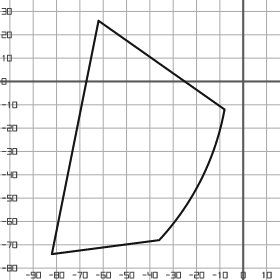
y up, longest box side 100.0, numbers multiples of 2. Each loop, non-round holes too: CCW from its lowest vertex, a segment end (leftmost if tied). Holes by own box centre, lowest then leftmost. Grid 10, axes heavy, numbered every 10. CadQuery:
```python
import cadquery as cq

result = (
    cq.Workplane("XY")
    .moveTo(-82.0, -74.0)
    .lineTo(-36.0, -68.0)
    .threePointArc((-18.0, -42.0), (-8.0, -12.0))
    .lineTo(-62.0, 26.0)
    .close()
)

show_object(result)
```